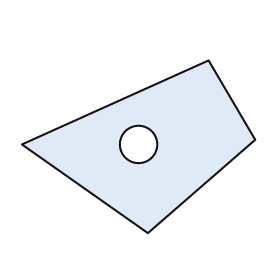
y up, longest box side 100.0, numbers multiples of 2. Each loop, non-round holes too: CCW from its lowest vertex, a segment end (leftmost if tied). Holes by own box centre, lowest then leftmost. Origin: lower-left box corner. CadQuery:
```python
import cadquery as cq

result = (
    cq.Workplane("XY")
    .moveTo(54.0, 0.0)
    .lineTo(100.0, 40.0)
    .lineTo(80.0, 74.0)
    .lineTo(0.0, 38.0)
    .close()
    .moveTo(50.0, 38.0)
    .circle(8.0)
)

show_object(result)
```